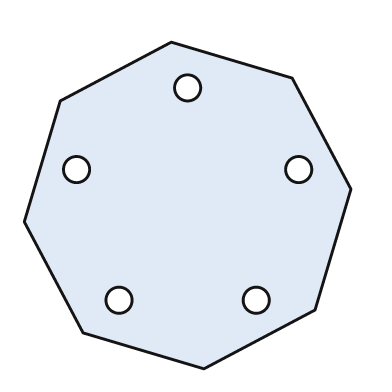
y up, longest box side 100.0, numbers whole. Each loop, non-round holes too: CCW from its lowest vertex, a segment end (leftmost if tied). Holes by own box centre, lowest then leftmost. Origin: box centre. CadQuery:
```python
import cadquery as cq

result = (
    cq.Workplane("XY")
    .moveTo(5.0, -50.0)
    .lineTo(39.0, -32.0)
    .lineTo(50.0, 5.0)
    .lineTo(32.0, 39.0)
    .lineTo(-5.0, 50.0)
    .lineTo(-39.0, 32.0)
    .lineTo(-50.0, -5.0)
    .lineTo(-32.0, -39.0)
    .close()
    .moveTo(-21.0, -29.0)
    .circle(4.0)
    .moveTo(21.0, -29.0)
    .circle(4.0)
    .moveTo(-34.0, 11.0)
    .circle(4.0)
    .moveTo(34.0, 11.0)
    .circle(4.0)
    .moveTo(0.0, 36.0)
    .circle(4.0)
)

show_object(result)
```